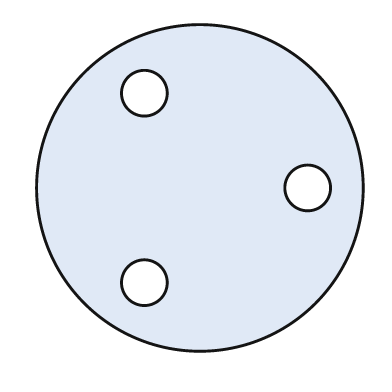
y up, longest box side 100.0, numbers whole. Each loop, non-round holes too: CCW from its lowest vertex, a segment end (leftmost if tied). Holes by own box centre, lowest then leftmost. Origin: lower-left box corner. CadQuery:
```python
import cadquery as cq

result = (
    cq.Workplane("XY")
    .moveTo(50.0, 50.0)
    .circle(50.0)
    .moveTo(33.0, 21.0)
    .circle(7.0)
    .moveTo(83.0, 50.0)
    .circle(7.0)
    .moveTo(33.0, 79.0)
    .circle(7.0)
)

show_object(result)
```